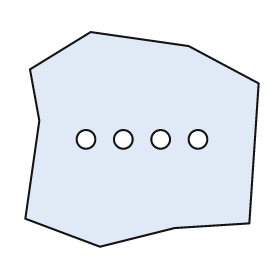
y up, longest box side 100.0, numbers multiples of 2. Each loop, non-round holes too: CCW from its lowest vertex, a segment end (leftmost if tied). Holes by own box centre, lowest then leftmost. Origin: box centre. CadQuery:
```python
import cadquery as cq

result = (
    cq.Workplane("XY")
    .moveTo(-18.0, -46.0)
    .lineTo(14.0, -38.0)
    .lineTo(46.0, -36.0)
    .lineTo(50.0, 24.0)
    .lineTo(20.0, 40.0)
    .lineTo(-22.0, 46.0)
    .lineTo(-48.0, 30.0)
    .lineTo(-44.0, 8.0)
    .lineTo(-50.0, -34.0)
    .close()
    .moveTo(-24.0, 0.0)
    .circle(4.0)
    .moveTo(-8.0, 0.0)
    .circle(4.0)
    .moveTo(8.0, 0.0)
    .circle(4.0)
    .moveTo(24.0, 0.0)
    .circle(4.0)
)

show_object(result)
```